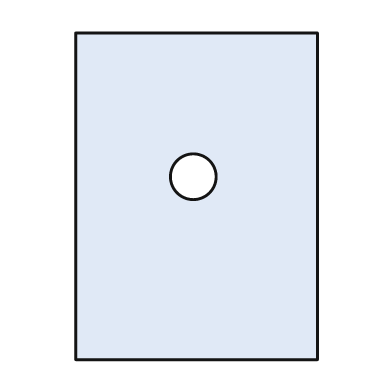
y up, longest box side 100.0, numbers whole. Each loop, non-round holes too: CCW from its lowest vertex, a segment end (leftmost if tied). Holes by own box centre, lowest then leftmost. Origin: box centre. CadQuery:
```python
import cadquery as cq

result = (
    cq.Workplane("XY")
    .moveTo(-37.0, -50.0)
    .lineTo(37.0, -50.0)
    .lineTo(37.0, 50.0)
    .lineTo(-37.0, 50.0)
    .close()
    .moveTo(-1.0, 6.0)
    .circle(7.0)
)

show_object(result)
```